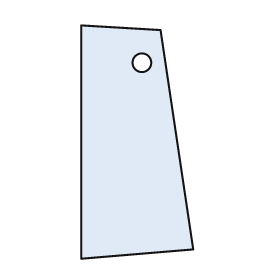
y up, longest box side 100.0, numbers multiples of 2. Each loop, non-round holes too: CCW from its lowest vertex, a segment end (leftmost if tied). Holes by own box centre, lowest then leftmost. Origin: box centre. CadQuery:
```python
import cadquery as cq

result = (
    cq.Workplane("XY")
    .moveTo(-24.0, -50.0)
    .lineTo(24.0, -46.0)
    .lineTo(10.0, 48.0)
    .lineTo(-24.0, 50.0)
    .close()
    .moveTo(2.0, 34.0)
    .circle(4.0)
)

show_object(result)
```